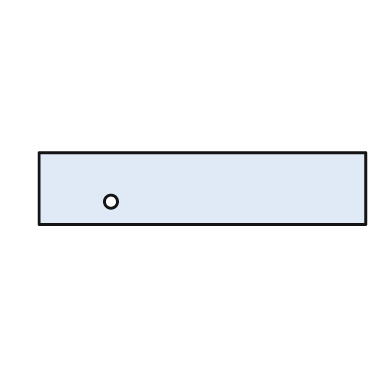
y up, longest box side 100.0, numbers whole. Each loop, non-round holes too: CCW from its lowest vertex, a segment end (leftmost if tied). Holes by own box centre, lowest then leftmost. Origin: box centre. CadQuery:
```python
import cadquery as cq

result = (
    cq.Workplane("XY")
    .moveTo(-50.0, -11.0)
    .lineTo(50.0, -11.0)
    .lineTo(50.0, 11.0)
    .lineTo(-50.0, 11.0)
    .close()
    .moveTo(-28.0, -4.0)
    .circle(2.0)
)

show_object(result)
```